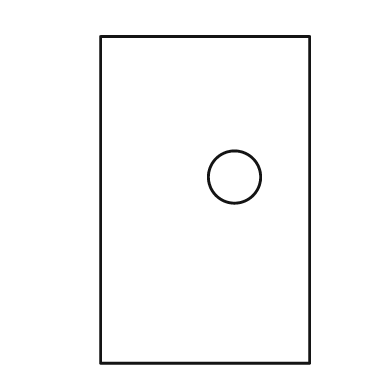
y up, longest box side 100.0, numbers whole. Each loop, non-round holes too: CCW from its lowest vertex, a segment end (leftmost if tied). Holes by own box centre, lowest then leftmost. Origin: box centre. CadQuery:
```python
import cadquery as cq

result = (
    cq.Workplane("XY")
    .moveTo(-32.0, -50.0)
    .lineTo(32.0, -50.0)
    .lineTo(32.0, 50.0)
    .lineTo(-32.0, 50.0)
    .close()
    .moveTo(9.0, 7.0)
    .circle(8.0)
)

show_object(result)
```